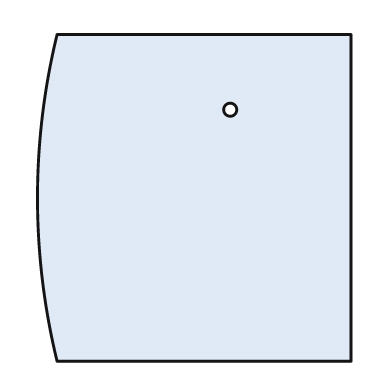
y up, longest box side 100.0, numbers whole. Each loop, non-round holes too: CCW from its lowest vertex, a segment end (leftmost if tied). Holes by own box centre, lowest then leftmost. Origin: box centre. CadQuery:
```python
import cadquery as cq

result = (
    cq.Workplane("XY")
    .moveTo(-42.0, -50.0)
    .lineTo(48.0, -50.0)
    .lineTo(48.0, 50.0)
    .lineTo(-42.0, 50.0)
    .threePointArc((-48.0, 0.0), (-42.0, -50.0))
    .close()
    .moveTo(11.0, 27.0)
    .circle(2.0)
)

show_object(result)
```